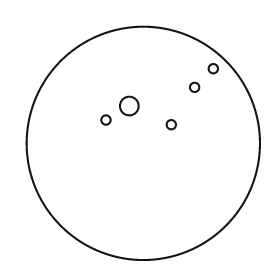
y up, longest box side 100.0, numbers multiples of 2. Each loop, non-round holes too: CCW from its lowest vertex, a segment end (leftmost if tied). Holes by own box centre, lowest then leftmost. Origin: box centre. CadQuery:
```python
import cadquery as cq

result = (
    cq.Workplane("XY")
    .moveTo(0.0, 0.0)
    .circle(50.0)
    .moveTo(12.0, 8.0)
    .circle(2.0)
    .moveTo(-16.0, 10.0)
    .circle(2.0)
    .moveTo(-6.0, 16.0)
    .circle(4.0)
    .moveTo(22.0, 24.0)
    .circle(2.0)
    .moveTo(30.0, 32.0)
    .circle(2.0)
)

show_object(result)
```